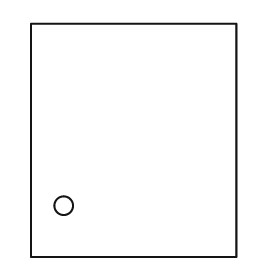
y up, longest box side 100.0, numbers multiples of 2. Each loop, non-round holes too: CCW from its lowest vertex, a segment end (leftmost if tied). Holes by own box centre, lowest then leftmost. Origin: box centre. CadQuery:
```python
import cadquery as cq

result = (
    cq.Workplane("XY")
    .moveTo(-44.0, -50.0)
    .lineTo(44.0, -50.0)
    .lineTo(44.0, 50.0)
    .lineTo(-44.0, 50.0)
    .close()
    .moveTo(-30.0, -28.0)
    .circle(4.0)
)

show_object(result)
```